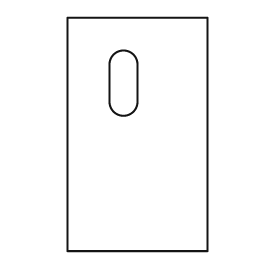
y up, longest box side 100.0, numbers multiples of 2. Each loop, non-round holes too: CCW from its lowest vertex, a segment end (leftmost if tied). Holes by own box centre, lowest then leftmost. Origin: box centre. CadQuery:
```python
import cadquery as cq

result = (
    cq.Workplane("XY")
    .moveTo(-30.0, -50.0)
    .lineTo(30.0, -50.0)
    .lineTo(30.0, 50.0)
    .lineTo(-30.0, 50.0)
    .close()
    .moveTo(-12.0, 14.0)
    .threePointArc((-6.0, 8.0), (0.0, 14.0))
    .lineTo(0.0, 30.0)
    .threePointArc((-6.0, 36.0), (-12.0, 30.0))
    .close()
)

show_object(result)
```